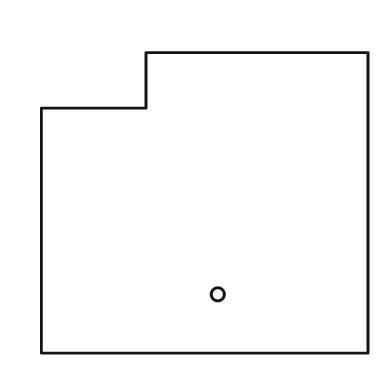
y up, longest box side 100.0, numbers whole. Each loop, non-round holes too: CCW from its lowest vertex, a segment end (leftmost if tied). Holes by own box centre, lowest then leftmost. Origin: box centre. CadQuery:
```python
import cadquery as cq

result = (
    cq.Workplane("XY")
    .moveTo(-50.0, -46.0)
    .lineTo(50.0, -46.0)
    .lineTo(50.0, 46.0)
    .lineTo(-18.0, 46.0)
    .lineTo(-18.0, 29.0)
    .lineTo(-50.0, 29.0)
    .close()
    .moveTo(4.0, -28.0)
    .circle(2.0)
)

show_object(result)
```